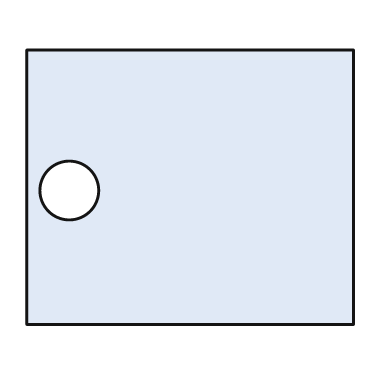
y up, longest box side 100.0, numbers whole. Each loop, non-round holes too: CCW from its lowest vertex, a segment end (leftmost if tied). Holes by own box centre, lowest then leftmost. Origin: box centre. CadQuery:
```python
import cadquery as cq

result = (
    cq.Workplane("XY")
    .moveTo(-50.0, -42.0)
    .lineTo(50.0, -42.0)
    .lineTo(50.0, 42.0)
    .lineTo(-50.0, 42.0)
    .close()
    .moveTo(-37.0, -1.0)
    .circle(9.0)
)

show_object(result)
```